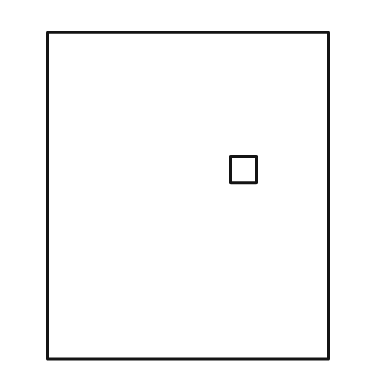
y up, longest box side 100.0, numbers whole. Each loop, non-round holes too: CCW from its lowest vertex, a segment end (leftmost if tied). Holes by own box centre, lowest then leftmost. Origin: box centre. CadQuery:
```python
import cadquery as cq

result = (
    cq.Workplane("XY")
    .moveTo(-43.0, -50.0)
    .lineTo(43.0, -50.0)
    .lineTo(43.0, 50.0)
    .lineTo(-43.0, 50.0)
    .close()
    .moveTo(13.0, 4.0)
    .lineTo(21.0, 4.0)
    .lineTo(21.0, 12.0)
    .lineTo(13.0, 12.0)
    .close()
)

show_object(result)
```